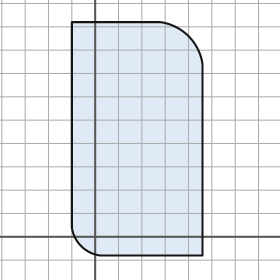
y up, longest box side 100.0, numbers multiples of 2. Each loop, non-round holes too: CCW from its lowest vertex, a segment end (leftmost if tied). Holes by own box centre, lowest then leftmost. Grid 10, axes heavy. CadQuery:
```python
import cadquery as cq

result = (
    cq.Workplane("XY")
    .moveTo(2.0, -8.0)
    .lineTo(46.0, -8.0)
    .lineTo(46.0, 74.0)
    .threePointArc((40.0, 86.0), (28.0, 92.0))
    .lineTo(-10.0, 92.0)
    .lineTo(-10.0, 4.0)
    .threePointArc((-6.0, -4.0), (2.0, -8.0))
    .close()
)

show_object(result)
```